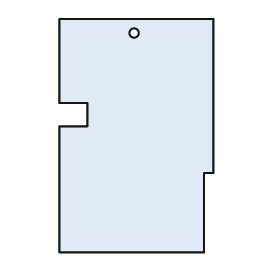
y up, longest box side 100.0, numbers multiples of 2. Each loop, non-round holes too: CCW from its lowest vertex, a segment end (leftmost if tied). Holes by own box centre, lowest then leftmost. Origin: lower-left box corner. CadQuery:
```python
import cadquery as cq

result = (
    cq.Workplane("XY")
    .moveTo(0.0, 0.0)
    .lineTo(62.0, 0.0)
    .lineTo(62.0, 34.0)
    .lineTo(66.0, 34.0)
    .lineTo(66.0, 100.0)
    .lineTo(0.0, 100.0)
    .lineTo(0.0, 64.0)
    .lineTo(12.0, 64.0)
    .lineTo(12.0, 54.0)
    .lineTo(0.0, 54.0)
    .close()
    .moveTo(32.0, 94.0)
    .circle(2.0)
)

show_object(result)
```